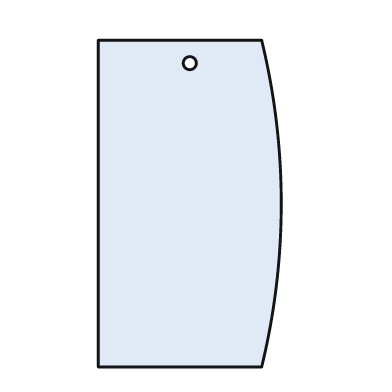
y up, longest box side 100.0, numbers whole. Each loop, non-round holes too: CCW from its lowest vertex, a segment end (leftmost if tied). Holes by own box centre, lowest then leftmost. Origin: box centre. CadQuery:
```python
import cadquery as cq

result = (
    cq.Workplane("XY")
    .moveTo(-28.0, -50.0)
    .lineTo(22.0, -50.0)
    .threePointArc((28.0, 0.0), (22.0, 50.0))
    .lineTo(-28.0, 50.0)
    .close()
    .moveTo(0.0, 43.0)
    .circle(2.0)
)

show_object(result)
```